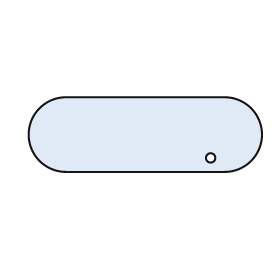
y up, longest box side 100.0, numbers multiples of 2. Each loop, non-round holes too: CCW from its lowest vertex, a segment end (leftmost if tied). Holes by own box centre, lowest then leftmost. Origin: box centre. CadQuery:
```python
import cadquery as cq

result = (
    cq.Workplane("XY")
    .moveTo(-34.0, -16.0)
    .lineTo(34.0, -16.0)
    .threePointArc((50.0, 0.0), (34.0, 16.0))
    .lineTo(-34.0, 16.0)
    .threePointArc((-50.0, 0.0), (-34.0, -16.0))
    .close()
    .moveTo(28.0, -10.0)
    .circle(2.0)
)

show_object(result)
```